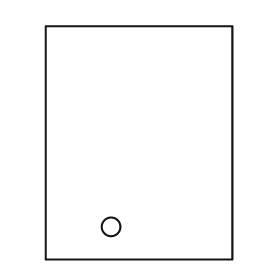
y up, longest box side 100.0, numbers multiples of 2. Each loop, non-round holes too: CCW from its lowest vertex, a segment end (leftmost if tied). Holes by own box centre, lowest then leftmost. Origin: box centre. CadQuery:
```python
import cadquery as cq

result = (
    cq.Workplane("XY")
    .moveTo(-40.0, -50.0)
    .lineTo(40.0, -50.0)
    .lineTo(40.0, 50.0)
    .lineTo(-40.0, 50.0)
    .close()
    .moveTo(-12.0, -36.0)
    .circle(4.0)
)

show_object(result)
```